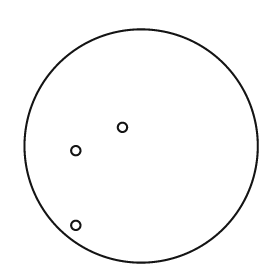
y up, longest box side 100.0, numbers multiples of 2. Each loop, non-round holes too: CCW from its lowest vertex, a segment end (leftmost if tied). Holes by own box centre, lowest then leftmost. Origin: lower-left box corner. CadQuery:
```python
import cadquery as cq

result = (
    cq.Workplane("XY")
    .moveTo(50.0, 50.0)
    .circle(50.0)
    .moveTo(22.0, 16.0)
    .circle(2.0)
    .moveTo(22.0, 48.0)
    .circle(2.0)
    .moveTo(42.0, 58.0)
    .circle(2.0)
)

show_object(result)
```